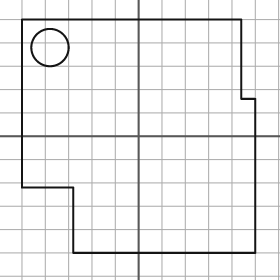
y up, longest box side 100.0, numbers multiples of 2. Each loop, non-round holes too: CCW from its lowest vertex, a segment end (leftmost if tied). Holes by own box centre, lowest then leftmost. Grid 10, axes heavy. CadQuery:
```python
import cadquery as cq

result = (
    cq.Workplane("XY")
    .moveTo(-28.0, -50.0)
    .lineTo(50.0, -50.0)
    .lineTo(50.0, 16.0)
    .lineTo(44.0, 16.0)
    .lineTo(44.0, 50.0)
    .lineTo(-50.0, 50.0)
    .lineTo(-50.0, -22.0)
    .lineTo(-28.0, -22.0)
    .close()
    .moveTo(-38.0, 38.0)
    .circle(8.0)
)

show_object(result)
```